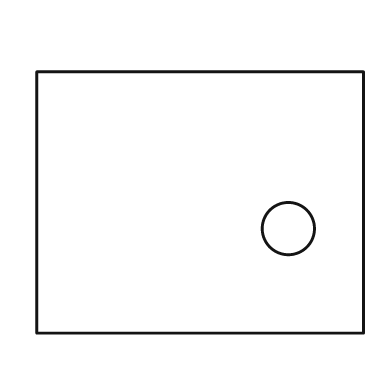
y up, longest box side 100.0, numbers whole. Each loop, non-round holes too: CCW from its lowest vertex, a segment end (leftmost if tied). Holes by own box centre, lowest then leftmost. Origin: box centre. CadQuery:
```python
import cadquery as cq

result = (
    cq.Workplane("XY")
    .moveTo(-50.0, -40.0)
    .lineTo(50.0, -40.0)
    .lineTo(50.0, 40.0)
    .lineTo(-50.0, 40.0)
    .close()
    .moveTo(27.0, -8.0)
    .circle(8.0)
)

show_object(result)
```